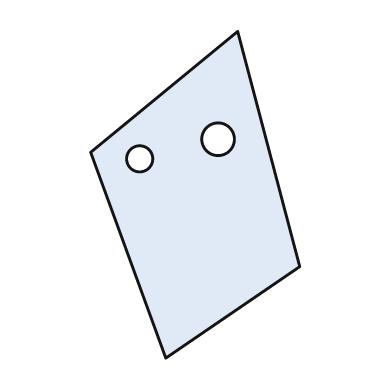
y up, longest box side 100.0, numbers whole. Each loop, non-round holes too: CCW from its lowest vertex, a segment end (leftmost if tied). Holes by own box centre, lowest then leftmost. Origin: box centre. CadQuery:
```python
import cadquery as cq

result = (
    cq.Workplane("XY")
    .moveTo(-9.0, -50.0)
    .lineTo(32.0, -22.0)
    .lineTo(13.0, 50.0)
    .lineTo(-32.0, 13.0)
    .close()
    .moveTo(-17.0, 11.0)
    .circle(4.0)
    .moveTo(7.0, 17.0)
    .circle(5.0)
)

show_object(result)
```